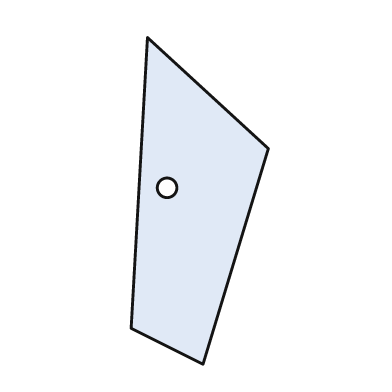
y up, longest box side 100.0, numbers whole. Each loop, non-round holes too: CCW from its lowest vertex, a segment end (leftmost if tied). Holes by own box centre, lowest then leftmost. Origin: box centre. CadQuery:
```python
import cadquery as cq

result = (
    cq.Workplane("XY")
    .moveTo(1.0, -50.0)
    .lineTo(21.0, 16.0)
    .lineTo(-16.0, 50.0)
    .lineTo(-21.0, -39.0)
    .close()
    .moveTo(-10.0, 4.0)
    .circle(3.0)
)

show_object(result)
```